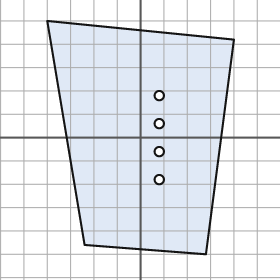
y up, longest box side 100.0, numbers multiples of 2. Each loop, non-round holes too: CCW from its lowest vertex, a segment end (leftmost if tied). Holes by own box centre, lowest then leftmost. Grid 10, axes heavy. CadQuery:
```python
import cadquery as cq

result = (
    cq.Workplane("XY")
    .moveTo(28.0, -50.0)
    .lineTo(40.0, 42.0)
    .lineTo(-40.0, 50.0)
    .lineTo(-24.0, -46.0)
    .close()
    .moveTo(8.0, -18.0)
    .circle(2.0)
    .moveTo(8.0, -6.0)
    .circle(2.0)
    .moveTo(8.0, 6.0)
    .circle(2.0)
    .moveTo(8.0, 18.0)
    .circle(2.0)
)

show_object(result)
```